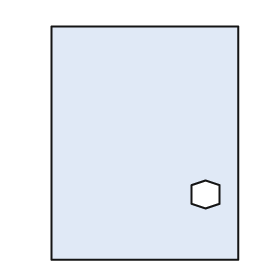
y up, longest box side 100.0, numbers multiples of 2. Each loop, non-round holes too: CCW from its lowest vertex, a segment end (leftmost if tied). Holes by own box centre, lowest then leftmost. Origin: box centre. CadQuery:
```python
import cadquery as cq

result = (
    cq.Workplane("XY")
    .moveTo(-40.0, -50.0)
    .lineTo(40.0, -50.0)
    .lineTo(40.0, 50.0)
    .lineTo(-40.0, 50.0)
    .close()
    .moveTo(26.0, -28.0)
    .lineTo(32.0, -26.0)
    .lineTo(32.0, -18.0)
    .lineTo(26.0, -16.0)
    .lineTo(20.0, -18.0)
    .lineTo(20.0, -26.0)
    .close()
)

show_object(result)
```